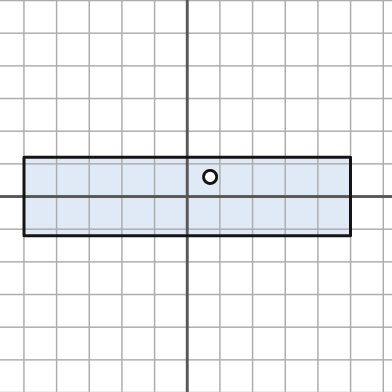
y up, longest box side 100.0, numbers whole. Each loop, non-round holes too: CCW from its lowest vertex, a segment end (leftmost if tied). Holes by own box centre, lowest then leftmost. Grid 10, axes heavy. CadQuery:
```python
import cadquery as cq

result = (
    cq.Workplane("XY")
    .moveTo(-50.0, -12.0)
    .lineTo(50.0, -12.0)
    .lineTo(50.0, 12.0)
    .lineTo(-50.0, 12.0)
    .close()
    .moveTo(7.0, 6.0)
    .circle(2.0)
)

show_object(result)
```